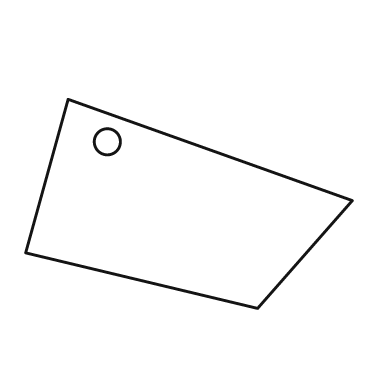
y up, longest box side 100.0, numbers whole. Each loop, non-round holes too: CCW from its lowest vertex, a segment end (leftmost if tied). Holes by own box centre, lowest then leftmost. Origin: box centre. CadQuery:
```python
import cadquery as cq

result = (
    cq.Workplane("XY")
    .moveTo(21.0, -32.0)
    .lineTo(50.0, 1.0)
    .lineTo(-37.0, 32.0)
    .lineTo(-50.0, -15.0)
    .close()
    .moveTo(-25.0, 19.0)
    .circle(4.0)
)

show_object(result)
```